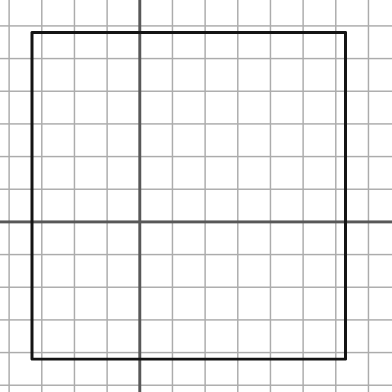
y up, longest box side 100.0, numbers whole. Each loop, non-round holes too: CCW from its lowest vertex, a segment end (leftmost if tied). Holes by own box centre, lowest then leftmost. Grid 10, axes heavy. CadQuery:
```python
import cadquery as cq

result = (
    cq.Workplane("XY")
    .moveTo(-33.0, -42.0)
    .lineTo(63.0, -42.0)
    .lineTo(63.0, 58.0)
    .lineTo(-33.0, 58.0)
    .close()
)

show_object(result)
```